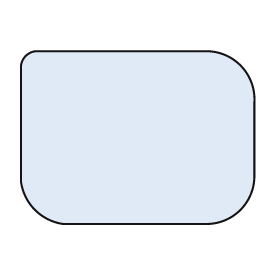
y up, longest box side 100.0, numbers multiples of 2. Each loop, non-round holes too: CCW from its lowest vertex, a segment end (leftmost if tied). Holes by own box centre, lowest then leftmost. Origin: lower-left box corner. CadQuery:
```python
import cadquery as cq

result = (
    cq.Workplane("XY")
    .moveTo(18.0, 0.0)
    .lineTo(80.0, 0.0)
    .threePointArc((94.0, 6.0), (100.0, 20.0))
    .lineTo(100.0, 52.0)
    .threePointArc((94.0, 68.0), (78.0, 74.0))
    .lineTo(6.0, 74.0)
    .threePointArc((2.0, 72.0), (0.0, 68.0))
    .lineTo(0.0, 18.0)
    .threePointArc((6.0, 6.0), (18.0, 0.0))
    .close()
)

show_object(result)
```